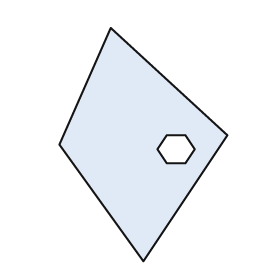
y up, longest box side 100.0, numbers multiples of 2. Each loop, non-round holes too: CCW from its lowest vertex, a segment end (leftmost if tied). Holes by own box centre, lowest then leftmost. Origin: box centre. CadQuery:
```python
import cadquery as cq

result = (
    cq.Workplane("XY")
    .moveTo(0.0, -50.0)
    .lineTo(36.0, 4.0)
    .lineTo(-14.0, 50.0)
    .lineTo(-36.0, 0.0)
    .close()
    .moveTo(10.0, -8.0)
    .lineTo(18.0, -8.0)
    .lineTo(22.0, -2.0)
    .lineTo(18.0, 4.0)
    .lineTo(10.0, 4.0)
    .lineTo(6.0, -2.0)
    .close()
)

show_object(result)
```